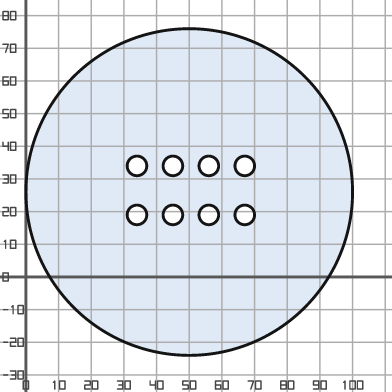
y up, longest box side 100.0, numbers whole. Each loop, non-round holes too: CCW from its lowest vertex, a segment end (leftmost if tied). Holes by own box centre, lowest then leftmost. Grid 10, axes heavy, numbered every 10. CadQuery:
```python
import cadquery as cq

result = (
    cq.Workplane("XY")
    .moveTo(50.0, 26.0)
    .circle(50.0)
    .moveTo(34.0, 19.0)
    .circle(3.0)
    .moveTo(45.0, 19.0)
    .circle(3.0)
    .moveTo(56.0, 19.0)
    .circle(3.0)
    .moveTo(67.0, 19.0)
    .circle(3.0)
    .moveTo(34.0, 34.0)
    .circle(3.0)
    .moveTo(45.0, 34.0)
    .circle(3.0)
    .moveTo(56.0, 34.0)
    .circle(3.0)
    .moveTo(67.0, 34.0)
    .circle(3.0)
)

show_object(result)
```